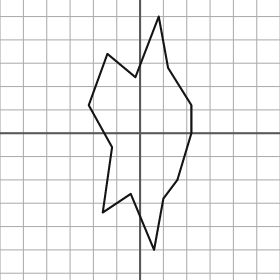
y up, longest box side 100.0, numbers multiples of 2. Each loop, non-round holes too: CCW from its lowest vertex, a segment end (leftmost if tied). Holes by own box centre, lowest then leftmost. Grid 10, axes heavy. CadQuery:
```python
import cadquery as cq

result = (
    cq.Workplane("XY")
    .moveTo(6.0, -50.0)
    .lineTo(10.0, -28.0)
    .lineTo(16.0, -20.0)
    .lineTo(22.0, 0.0)
    .lineTo(22.0, 12.0)
    .lineTo(12.0, 28.0)
    .lineTo(8.0, 50.0)
    .lineTo(-2.0, 24.0)
    .lineTo(-14.0, 34.0)
    .lineTo(-22.0, 12.0)
    .lineTo(-12.0, -6.0)
    .lineTo(-16.0, -34.0)
    .lineTo(-4.0, -26.0)
    .close()
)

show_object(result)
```